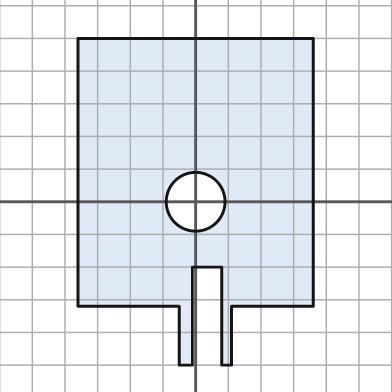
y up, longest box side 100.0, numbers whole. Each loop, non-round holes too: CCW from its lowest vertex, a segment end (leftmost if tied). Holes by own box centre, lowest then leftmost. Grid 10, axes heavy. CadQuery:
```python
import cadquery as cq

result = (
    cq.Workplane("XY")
    .moveTo(-5.0, -50.0)
    .lineTo(-1.0, -50.0)
    .lineTo(-1.0, -20.0)
    .lineTo(8.0, -20.0)
    .lineTo(8.0, -50.0)
    .lineTo(11.0, -50.0)
    .lineTo(11.0, -32.0)
    .lineTo(36.0, -32.0)
    .lineTo(36.0, 50.0)
    .lineTo(-36.0, 50.0)
    .lineTo(-36.0, -32.0)
    .lineTo(-5.0, -32.0)
    .close()
    .moveTo(0.0, 0.0)
    .circle(9.0)
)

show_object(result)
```